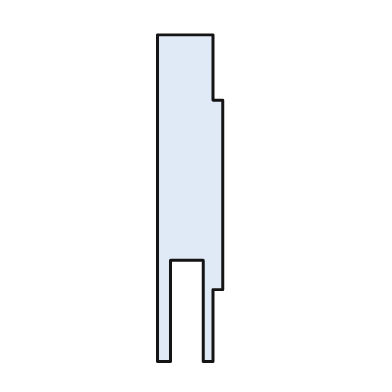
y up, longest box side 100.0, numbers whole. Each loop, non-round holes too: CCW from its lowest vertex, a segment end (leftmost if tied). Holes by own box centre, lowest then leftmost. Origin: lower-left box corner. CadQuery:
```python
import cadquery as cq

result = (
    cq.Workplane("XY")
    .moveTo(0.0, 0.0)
    .lineTo(4.0, 0.0)
    .lineTo(4.0, 31.0)
    .lineTo(14.0, 31.0)
    .lineTo(14.0, 0.0)
    .lineTo(17.0, 0.0)
    .lineTo(17.0, 22.0)
    .lineTo(20.0, 22.0)
    .lineTo(20.0, 80.0)
    .lineTo(17.0, 80.0)
    .lineTo(17.0, 100.0)
    .lineTo(0.0, 100.0)
    .close()
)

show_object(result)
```